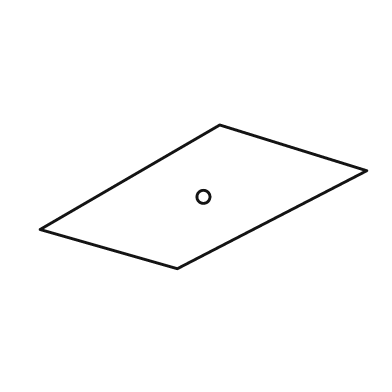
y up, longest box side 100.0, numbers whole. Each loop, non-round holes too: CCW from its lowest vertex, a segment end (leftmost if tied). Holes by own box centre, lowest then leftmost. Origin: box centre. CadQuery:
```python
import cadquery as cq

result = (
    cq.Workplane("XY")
    .moveTo(-8.0, -22.0)
    .lineTo(50.0, 8.0)
    .lineTo(5.0, 22.0)
    .lineTo(-50.0, -10.0)
    .close()
    .moveTo(0.0, 0.0)
    .circle(2.0)
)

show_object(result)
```